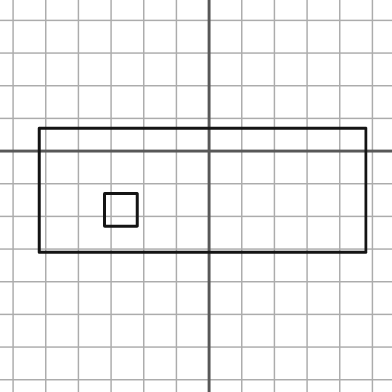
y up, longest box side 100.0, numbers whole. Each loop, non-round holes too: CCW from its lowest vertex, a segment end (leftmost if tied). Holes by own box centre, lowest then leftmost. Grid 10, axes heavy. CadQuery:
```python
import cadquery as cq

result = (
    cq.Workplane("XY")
    .moveTo(-52.0, -31.0)
    .lineTo(48.0, -31.0)
    .lineTo(48.0, 7.0)
    .lineTo(-52.0, 7.0)
    .close()
    .moveTo(-32.0, -23.0)
    .lineTo(-22.0, -23.0)
    .lineTo(-22.0, -13.0)
    .lineTo(-32.0, -13.0)
    .close()
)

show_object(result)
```